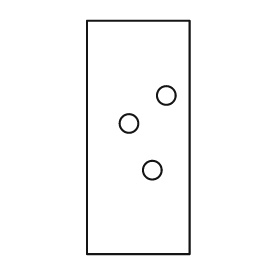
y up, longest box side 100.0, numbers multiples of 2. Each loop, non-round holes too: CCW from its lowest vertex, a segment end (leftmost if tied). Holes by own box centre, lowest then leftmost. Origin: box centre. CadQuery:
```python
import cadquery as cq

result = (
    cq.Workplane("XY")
    .moveTo(-22.0, -50.0)
    .lineTo(22.0, -50.0)
    .lineTo(22.0, 50.0)
    .lineTo(-22.0, 50.0)
    .close()
    .moveTo(6.0, -14.0)
    .circle(4.0)
    .moveTo(-4.0, 6.0)
    .circle(4.0)
    .moveTo(12.0, 18.0)
    .circle(4.0)
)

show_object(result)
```